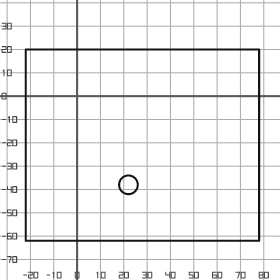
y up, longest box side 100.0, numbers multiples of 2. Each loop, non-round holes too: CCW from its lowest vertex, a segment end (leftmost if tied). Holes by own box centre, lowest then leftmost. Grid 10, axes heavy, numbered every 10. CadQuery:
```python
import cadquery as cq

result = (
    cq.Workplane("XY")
    .moveTo(-22.0, -62.0)
    .lineTo(78.0, -62.0)
    .lineTo(78.0, 20.0)
    .lineTo(-22.0, 20.0)
    .close()
    .moveTo(22.0, -38.0)
    .circle(4.0)
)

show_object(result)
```